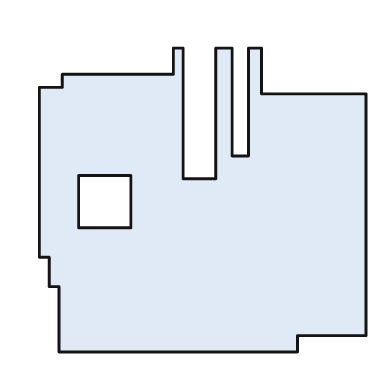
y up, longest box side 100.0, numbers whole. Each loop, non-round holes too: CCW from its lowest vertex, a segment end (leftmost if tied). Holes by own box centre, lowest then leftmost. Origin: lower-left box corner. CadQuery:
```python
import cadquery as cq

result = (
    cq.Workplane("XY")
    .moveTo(6.0, 0.0)
    .lineTo(79.0, 0.0)
    .lineTo(79.0, 5.0)
    .lineTo(100.0, 5.0)
    .lineTo(100.0, 79.0)
    .lineTo(68.0, 79.0)
    .lineTo(68.0, 93.0)
    .lineTo(64.0, 93.0)
    .lineTo(64.0, 60.0)
    .lineTo(59.0, 60.0)
    .lineTo(59.0, 93.0)
    .lineTo(54.0, 93.0)
    .lineTo(54.0, 53.0)
    .lineTo(44.0, 53.0)
    .lineTo(44.0, 93.0)
    .lineTo(41.0, 93.0)
    .lineTo(41.0, 85.0)
    .lineTo(7.0, 85.0)
    .lineTo(7.0, 81.0)
    .lineTo(0.0, 81.0)
    .lineTo(0.0, 29.0)
    .lineTo(3.0, 29.0)
    .lineTo(3.0, 20.0)
    .lineTo(6.0, 20.0)
    .close()
    .moveTo(12.0, 38.0)
    .lineTo(28.0, 38.0)
    .lineTo(28.0, 54.0)
    .lineTo(12.0, 54.0)
    .close()
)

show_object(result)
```